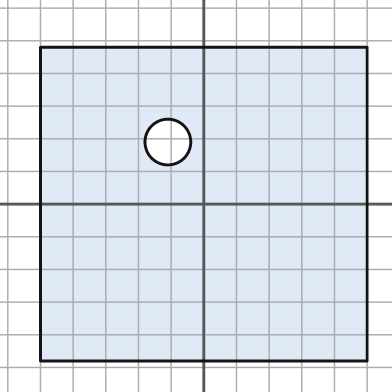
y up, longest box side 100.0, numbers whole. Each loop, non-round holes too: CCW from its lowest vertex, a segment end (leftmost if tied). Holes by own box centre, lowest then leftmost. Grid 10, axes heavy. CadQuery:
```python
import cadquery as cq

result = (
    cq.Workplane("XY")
    .moveTo(-50.0, -48.0)
    .lineTo(50.0, -48.0)
    .lineTo(50.0, 48.0)
    .lineTo(-50.0, 48.0)
    .close()
    .moveTo(-11.0, 19.0)
    .circle(7.0)
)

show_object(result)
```